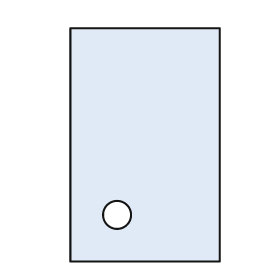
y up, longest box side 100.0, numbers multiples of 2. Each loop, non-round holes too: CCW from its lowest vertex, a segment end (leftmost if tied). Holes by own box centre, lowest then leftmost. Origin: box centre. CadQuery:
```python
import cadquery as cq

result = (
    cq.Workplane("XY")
    .moveTo(-32.0, -50.0)
    .lineTo(32.0, -50.0)
    .lineTo(32.0, 50.0)
    .lineTo(-32.0, 50.0)
    .close()
    .moveTo(-12.0, -30.0)
    .circle(6.0)
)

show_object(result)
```